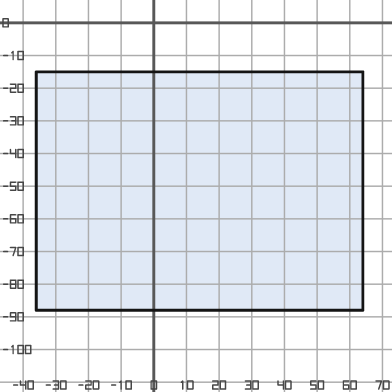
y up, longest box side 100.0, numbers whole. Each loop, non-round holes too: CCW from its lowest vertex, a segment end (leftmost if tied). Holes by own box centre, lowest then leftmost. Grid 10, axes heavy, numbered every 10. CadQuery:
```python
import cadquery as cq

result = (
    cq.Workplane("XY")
    .moveTo(-36.0, -88.0)
    .lineTo(64.0, -88.0)
    .lineTo(64.0, -15.0)
    .lineTo(-36.0, -15.0)
    .close()
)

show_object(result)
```